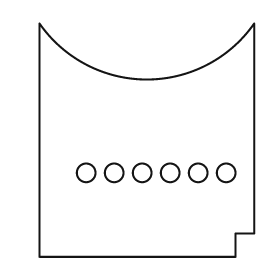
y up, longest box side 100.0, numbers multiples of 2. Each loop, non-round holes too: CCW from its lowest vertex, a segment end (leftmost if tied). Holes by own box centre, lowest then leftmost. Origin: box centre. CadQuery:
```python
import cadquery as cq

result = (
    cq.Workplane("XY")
    .moveTo(-46.0, -50.0)
    .lineTo(38.0, -50.0)
    .lineTo(38.0, -40.0)
    .lineTo(46.0, -40.0)
    .lineTo(46.0, 50.0)
    .threePointArc((0.0, 26.0), (-46.0, 50.0))
    .close()
    .moveTo(-26.0, -14.0)
    .circle(4.0)
    .moveTo(-14.0, -14.0)
    .circle(4.0)
    .moveTo(-2.0, -14.0)
    .circle(4.0)
    .moveTo(10.0, -14.0)
    .circle(4.0)
    .moveTo(22.0, -14.0)
    .circle(4.0)
    .moveTo(34.0, -14.0)
    .circle(4.0)
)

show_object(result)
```